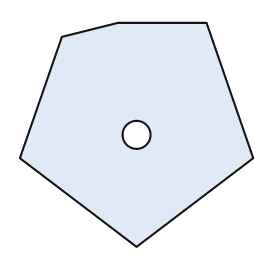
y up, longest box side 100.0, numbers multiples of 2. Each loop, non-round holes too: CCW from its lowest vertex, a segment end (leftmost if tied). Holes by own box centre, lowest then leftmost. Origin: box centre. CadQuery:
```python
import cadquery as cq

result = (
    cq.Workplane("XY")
    .moveTo(0.0, -48.0)
    .lineTo(50.0, -10.0)
    .lineTo(30.0, 48.0)
    .lineTo(-8.0, 48.0)
    .lineTo(-32.0, 42.0)
    .lineTo(-50.0, -10.0)
    .close()
    .moveTo(0.0, 0.0)
    .circle(6.0)
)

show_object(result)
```